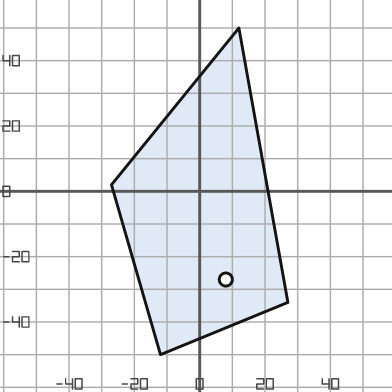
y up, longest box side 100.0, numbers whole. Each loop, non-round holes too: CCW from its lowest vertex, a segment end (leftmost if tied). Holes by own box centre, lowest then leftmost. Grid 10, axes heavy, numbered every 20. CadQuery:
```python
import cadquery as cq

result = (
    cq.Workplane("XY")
    .moveTo(-12.0, -50.0)
    .lineTo(27.0, -34.0)
    .lineTo(12.0, 50.0)
    .lineTo(-27.0, 2.0)
    .close()
    .moveTo(8.0, -27.0)
    .circle(2.0)
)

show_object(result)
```